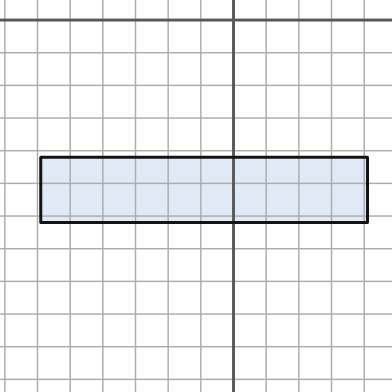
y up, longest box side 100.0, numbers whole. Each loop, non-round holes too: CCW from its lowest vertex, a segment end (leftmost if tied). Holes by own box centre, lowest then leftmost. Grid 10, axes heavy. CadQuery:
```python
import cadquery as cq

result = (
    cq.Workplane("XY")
    .moveTo(-59.0, -62.0)
    .lineTo(41.0, -62.0)
    .lineTo(41.0, -42.0)
    .lineTo(-59.0, -42.0)
    .close()
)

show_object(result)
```